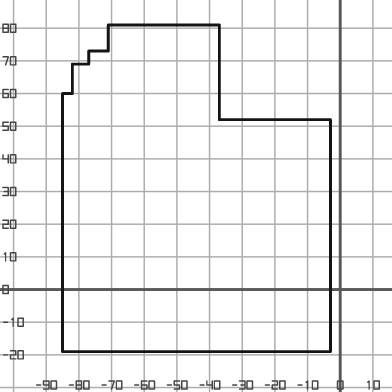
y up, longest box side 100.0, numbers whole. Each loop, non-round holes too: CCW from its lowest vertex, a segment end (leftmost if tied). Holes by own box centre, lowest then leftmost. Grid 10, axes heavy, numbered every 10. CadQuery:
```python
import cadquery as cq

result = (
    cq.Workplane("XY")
    .moveTo(-85.0, -19.0)
    .lineTo(-3.0, -19.0)
    .lineTo(-3.0, 52.0)
    .lineTo(-37.0, 52.0)
    .lineTo(-37.0, 81.0)
    .lineTo(-71.0, 81.0)
    .lineTo(-71.0, 73.0)
    .lineTo(-77.0, 73.0)
    .lineTo(-77.0, 69.0)
    .lineTo(-82.0, 69.0)
    .lineTo(-82.0, 60.0)
    .lineTo(-85.0, 60.0)
    .close()
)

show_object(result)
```